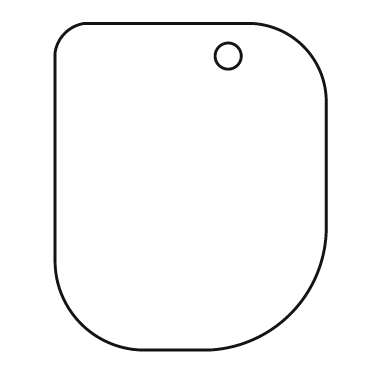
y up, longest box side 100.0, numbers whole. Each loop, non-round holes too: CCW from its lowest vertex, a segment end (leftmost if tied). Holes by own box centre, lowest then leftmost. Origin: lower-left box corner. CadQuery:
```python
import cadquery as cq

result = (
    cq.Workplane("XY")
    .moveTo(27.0, 0.0)
    .lineTo(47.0, 0.0)
    .threePointArc((72.0, 11.0), (83.0, 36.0))
    .lineTo(83.0, 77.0)
    .threePointArc((76.0, 93.0), (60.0, 100.0))
    .lineTo(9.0, 100.0)
    .threePointArc((3.0, 97.0), (0.0, 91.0))
    .lineTo(0.0, 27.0)
    .threePointArc((8.0, 8.0), (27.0, 0.0))
    .close()
    .moveTo(53.0, 90.0)
    .circle(4.0)
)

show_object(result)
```